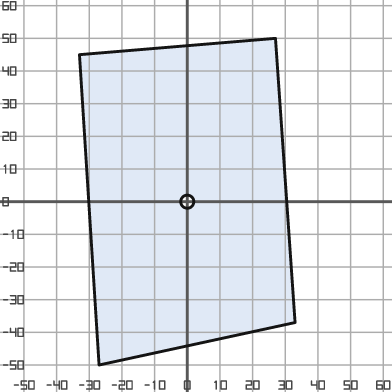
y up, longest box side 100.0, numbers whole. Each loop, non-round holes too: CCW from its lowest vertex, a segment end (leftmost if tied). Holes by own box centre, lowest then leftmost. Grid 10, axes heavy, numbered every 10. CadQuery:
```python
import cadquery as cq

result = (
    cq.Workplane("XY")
    .moveTo(-27.0, -50.0)
    .lineTo(33.0, -37.0)
    .lineTo(27.0, 50.0)
    .lineTo(-33.0, 45.0)
    .close()
    .moveTo(0.0, 0.0)
    .circle(2.0)
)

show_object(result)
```